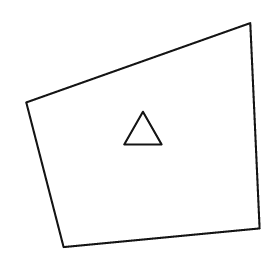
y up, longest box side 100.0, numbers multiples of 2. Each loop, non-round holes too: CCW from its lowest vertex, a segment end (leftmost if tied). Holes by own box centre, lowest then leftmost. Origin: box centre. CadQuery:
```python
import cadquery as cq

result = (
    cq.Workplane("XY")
    .moveTo(-34.0, -48.0)
    .lineTo(50.0, -40.0)
    .lineTo(46.0, 48.0)
    .lineTo(-50.0, 14.0)
    .close()
    .moveTo(-8.0, -4.0)
    .lineTo(8.0, -4.0)
    .lineTo(0.0, 10.0)
    .close()
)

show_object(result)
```